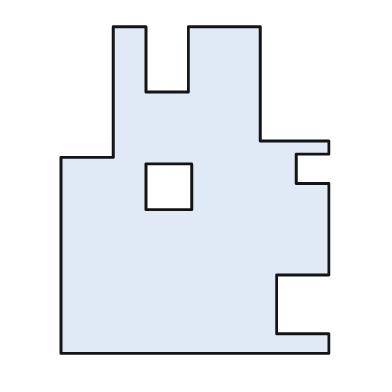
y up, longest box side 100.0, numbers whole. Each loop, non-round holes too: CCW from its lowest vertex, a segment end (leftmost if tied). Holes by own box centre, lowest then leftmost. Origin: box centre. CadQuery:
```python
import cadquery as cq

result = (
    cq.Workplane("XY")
    .moveTo(-41.0, -50.0)
    .lineTo(41.0, -50.0)
    .lineTo(41.0, -44.0)
    .lineTo(25.0, -44.0)
    .lineTo(25.0, -26.0)
    .lineTo(41.0, -26.0)
    .lineTo(41.0, 2.0)
    .lineTo(31.0, 2.0)
    .lineTo(31.0, 11.0)
    .lineTo(41.0, 11.0)
    .lineTo(41.0, 15.0)
    .lineTo(20.0, 15.0)
    .lineTo(20.0, 50.0)
    .lineTo(-2.0, 50.0)
    .lineTo(-2.0, 30.0)
    .lineTo(-15.0, 30.0)
    .lineTo(-15.0, 50.0)
    .lineTo(-25.0, 50.0)
    .lineTo(-25.0, 10.0)
    .lineTo(-41.0, 10.0)
    .close()
    .moveTo(-15.0, -6.0)
    .lineTo(-1.0, -6.0)
    .lineTo(-1.0, 8.0)
    .lineTo(-15.0, 8.0)
    .close()
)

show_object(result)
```